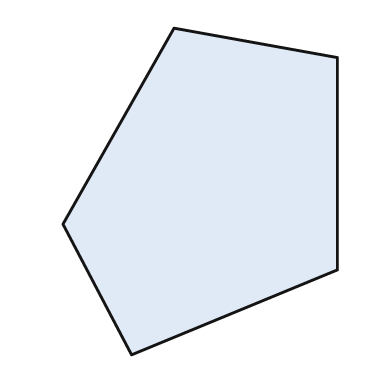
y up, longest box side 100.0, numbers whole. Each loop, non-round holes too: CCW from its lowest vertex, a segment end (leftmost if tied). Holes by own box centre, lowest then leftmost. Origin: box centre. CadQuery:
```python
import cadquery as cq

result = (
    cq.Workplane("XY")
    .moveTo(-21.0, -50.0)
    .lineTo(42.0, -24.0)
    .lineTo(42.0, 41.0)
    .lineTo(-8.0, 50.0)
    .lineTo(-42.0, -10.0)
    .close()
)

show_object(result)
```